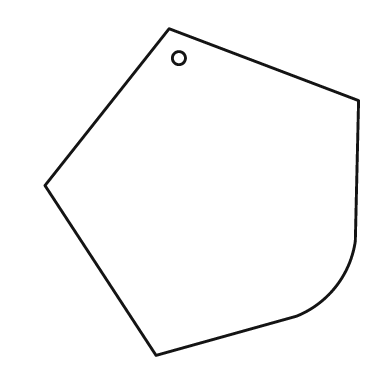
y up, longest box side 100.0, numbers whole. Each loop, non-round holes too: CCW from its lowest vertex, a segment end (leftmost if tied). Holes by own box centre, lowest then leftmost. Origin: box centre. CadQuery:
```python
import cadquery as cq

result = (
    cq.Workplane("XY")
    .moveTo(-14.0, -50.0)
    .lineTo(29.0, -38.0)
    .threePointArc((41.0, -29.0), (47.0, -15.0))
    .lineTo(48.0, 28.0)
    .lineTo(-10.0, 50.0)
    .lineTo(-48.0, 2.0)
    .close()
    .moveTo(-7.0, 41.0)
    .circle(2.0)
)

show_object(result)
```